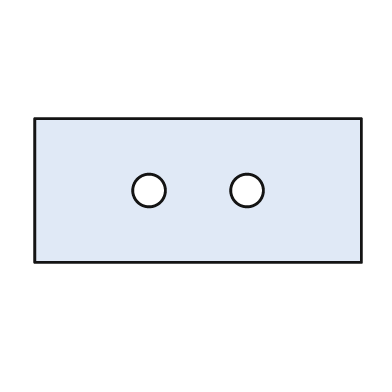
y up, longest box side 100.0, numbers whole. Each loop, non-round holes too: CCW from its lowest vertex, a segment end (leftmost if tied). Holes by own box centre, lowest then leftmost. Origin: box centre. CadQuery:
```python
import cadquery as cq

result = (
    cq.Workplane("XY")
    .moveTo(-50.0, -22.0)
    .lineTo(50.0, -22.0)
    .lineTo(50.0, 22.0)
    .lineTo(-50.0, 22.0)
    .close()
    .moveTo(-15.0, 0.0)
    .circle(5.0)
    .moveTo(15.0, 0.0)
    .circle(5.0)
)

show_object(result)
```